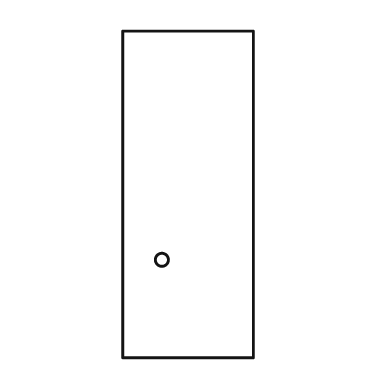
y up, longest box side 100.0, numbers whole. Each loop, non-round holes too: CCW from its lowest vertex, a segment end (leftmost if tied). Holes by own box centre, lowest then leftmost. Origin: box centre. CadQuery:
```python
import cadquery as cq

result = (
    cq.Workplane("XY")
    .moveTo(-20.0, -50.0)
    .lineTo(20.0, -50.0)
    .lineTo(20.0, 50.0)
    .lineTo(-20.0, 50.0)
    .close()
    .moveTo(-8.0, -20.0)
    .circle(2.0)
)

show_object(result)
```